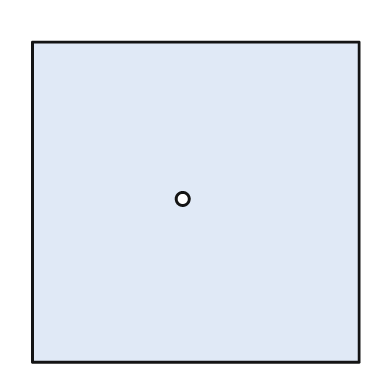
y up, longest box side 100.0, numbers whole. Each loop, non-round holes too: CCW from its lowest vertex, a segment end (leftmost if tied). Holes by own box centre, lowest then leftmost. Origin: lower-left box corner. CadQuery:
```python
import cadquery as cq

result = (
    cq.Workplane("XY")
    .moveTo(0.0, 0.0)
    .lineTo(100.0, 0.0)
    .lineTo(100.0, 98.0)
    .lineTo(0.0, 98.0)
    .close()
    .moveTo(46.0, 50.0)
    .circle(2.0)
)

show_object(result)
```